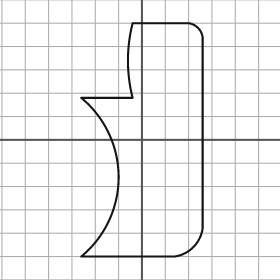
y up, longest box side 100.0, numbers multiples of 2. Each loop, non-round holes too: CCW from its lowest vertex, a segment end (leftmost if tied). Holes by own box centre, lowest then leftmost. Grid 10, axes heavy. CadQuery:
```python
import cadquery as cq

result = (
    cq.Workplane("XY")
    .moveTo(-26.0, -50.0)
    .lineTo(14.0, -50.0)
    .threePointArc((22.0, -46.0), (26.0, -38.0))
    .lineTo(26.0, 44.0)
    .threePointArc((24.0, 48.0), (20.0, 50.0))
    .lineTo(-4.0, 50.0)
    .threePointArc((-6.0, 34.0), (-4.0, 18.0))
    .lineTo(-26.0, 18.0)
    .threePointArc((-10.0, -16.0), (-26.0, -50.0))
    .close()
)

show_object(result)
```